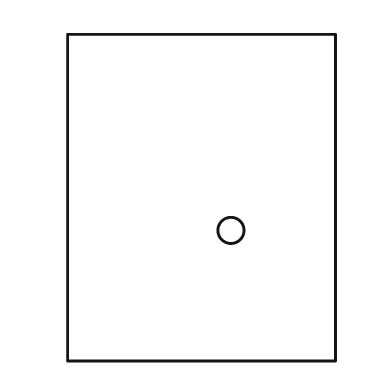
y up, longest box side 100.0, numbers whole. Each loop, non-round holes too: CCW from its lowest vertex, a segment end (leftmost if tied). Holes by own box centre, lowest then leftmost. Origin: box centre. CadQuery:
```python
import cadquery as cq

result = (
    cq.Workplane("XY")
    .moveTo(-41.0, -50.0)
    .lineTo(41.0, -50.0)
    .lineTo(41.0, 50.0)
    .lineTo(-41.0, 50.0)
    .close()
    .moveTo(9.0, -10.0)
    .circle(4.0)
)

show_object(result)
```